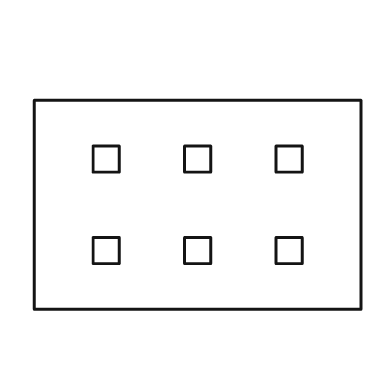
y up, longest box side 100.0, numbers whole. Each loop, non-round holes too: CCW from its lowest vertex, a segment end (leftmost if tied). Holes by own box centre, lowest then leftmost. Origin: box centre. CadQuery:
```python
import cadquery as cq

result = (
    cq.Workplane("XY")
    .moveTo(-50.0, -32.0)
    .lineTo(50.0, -32.0)
    .lineTo(50.0, 32.0)
    .lineTo(-50.0, 32.0)
    .close()
    .moveTo(-32.0, -18.0)
    .lineTo(-24.0, -18.0)
    .lineTo(-24.0, -10.0)
    .lineTo(-32.0, -10.0)
    .close()
    .moveTo(-4.0, -18.0)
    .lineTo(4.0, -18.0)
    .lineTo(4.0, -10.0)
    .lineTo(-4.0, -10.0)
    .close()
    .moveTo(24.0, -18.0)
    .lineTo(32.0, -18.0)
    .lineTo(32.0, -10.0)
    .lineTo(24.0, -10.0)
    .close()
    .moveTo(-32.0, 10.0)
    .lineTo(-24.0, 10.0)
    .lineTo(-24.0, 18.0)
    .lineTo(-32.0, 18.0)
    .close()
    .moveTo(-4.0, 10.0)
    .lineTo(4.0, 10.0)
    .lineTo(4.0, 18.0)
    .lineTo(-4.0, 18.0)
    .close()
    .moveTo(24.0, 10.0)
    .lineTo(32.0, 10.0)
    .lineTo(32.0, 18.0)
    .lineTo(24.0, 18.0)
    .close()
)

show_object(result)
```